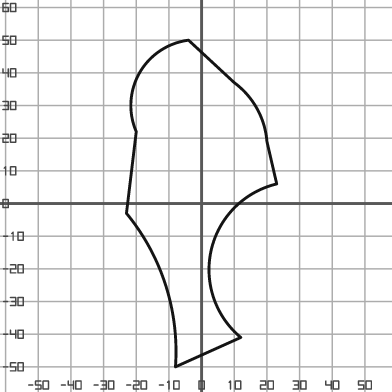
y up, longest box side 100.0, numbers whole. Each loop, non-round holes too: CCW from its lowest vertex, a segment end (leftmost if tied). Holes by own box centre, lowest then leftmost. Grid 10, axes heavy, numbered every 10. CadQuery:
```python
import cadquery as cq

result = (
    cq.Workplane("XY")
    .moveTo(-8.0, -50.0)
    .lineTo(12.0, -41.0)
    .threePointArc((3.0, -14.0), (23.0, 6.0))
    .lineTo(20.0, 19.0)
    .threePointArc((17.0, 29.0), (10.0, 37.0))
    .lineTo(-4.0, 50.0)
    .threePointArc((-19.0, 40.0), (-20.0, 22.0))
    .lineTo(-23.0, -3.0)
    .threePointArc((-11.0, -25.0), (-8.0, -50.0))
    .close()
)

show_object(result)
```